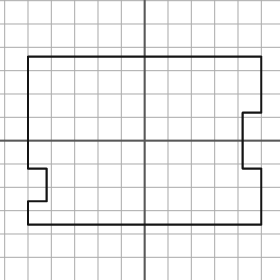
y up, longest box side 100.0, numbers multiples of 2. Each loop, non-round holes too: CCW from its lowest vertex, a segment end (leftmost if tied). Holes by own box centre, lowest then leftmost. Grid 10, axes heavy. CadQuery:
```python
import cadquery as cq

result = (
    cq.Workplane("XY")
    .moveTo(-50.0, -36.0)
    .lineTo(50.0, -36.0)
    .lineTo(50.0, -12.0)
    .lineTo(42.0, -12.0)
    .lineTo(42.0, 12.0)
    .lineTo(50.0, 12.0)
    .lineTo(50.0, 36.0)
    .lineTo(-50.0, 36.0)
    .lineTo(-50.0, -12.0)
    .lineTo(-42.0, -12.0)
    .lineTo(-42.0, -26.0)
    .lineTo(-50.0, -26.0)
    .close()
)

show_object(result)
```